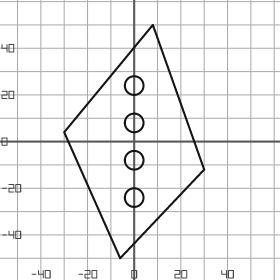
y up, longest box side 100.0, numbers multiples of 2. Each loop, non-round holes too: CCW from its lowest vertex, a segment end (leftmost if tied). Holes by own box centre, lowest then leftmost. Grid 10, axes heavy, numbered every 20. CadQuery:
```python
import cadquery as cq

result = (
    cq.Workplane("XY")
    .moveTo(-6.0, -50.0)
    .lineTo(30.0, -12.0)
    .lineTo(8.0, 50.0)
    .lineTo(-30.0, 4.0)
    .close()
    .moveTo(0.0, -24.0)
    .circle(4.0)
    .moveTo(0.0, -8.0)
    .circle(4.0)
    .moveTo(0.0, 8.0)
    .circle(4.0)
    .moveTo(0.0, 24.0)
    .circle(4.0)
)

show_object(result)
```